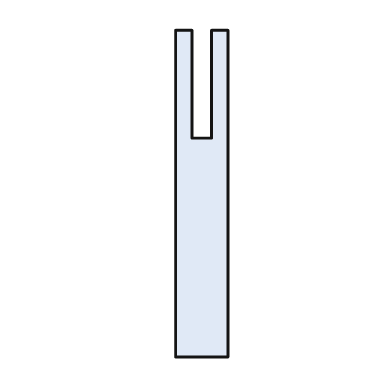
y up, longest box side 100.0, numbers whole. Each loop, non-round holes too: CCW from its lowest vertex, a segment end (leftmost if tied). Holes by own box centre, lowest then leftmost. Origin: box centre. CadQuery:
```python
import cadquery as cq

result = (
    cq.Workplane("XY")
    .moveTo(-8.0, -50.0)
    .lineTo(8.0, -50.0)
    .lineTo(8.0, 50.0)
    .lineTo(3.0, 50.0)
    .lineTo(3.0, 17.0)
    .lineTo(-3.0, 17.0)
    .lineTo(-3.0, 50.0)
    .lineTo(-8.0, 50.0)
    .close()
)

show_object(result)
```